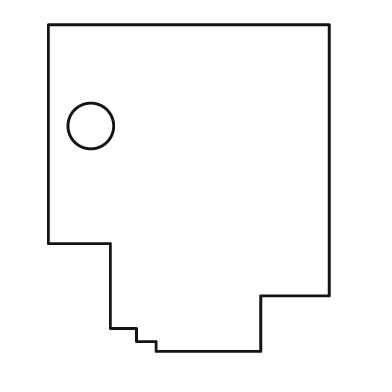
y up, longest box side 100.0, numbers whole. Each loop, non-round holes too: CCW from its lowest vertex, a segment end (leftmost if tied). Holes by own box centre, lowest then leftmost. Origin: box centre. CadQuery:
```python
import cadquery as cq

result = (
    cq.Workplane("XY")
    .moveTo(-10.0, -50.0)
    .lineTo(22.0, -50.0)
    .lineTo(22.0, -33.0)
    .lineTo(43.0, -33.0)
    .lineTo(43.0, 50.0)
    .lineTo(-43.0, 50.0)
    .lineTo(-43.0, -17.0)
    .lineTo(-24.0, -17.0)
    .lineTo(-24.0, -43.0)
    .lineTo(-16.0, -43.0)
    .lineTo(-16.0, -47.0)
    .lineTo(-10.0, -47.0)
    .close()
    .moveTo(-30.0, 19.0)
    .circle(7.0)
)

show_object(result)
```